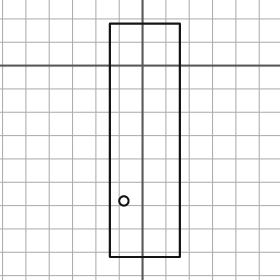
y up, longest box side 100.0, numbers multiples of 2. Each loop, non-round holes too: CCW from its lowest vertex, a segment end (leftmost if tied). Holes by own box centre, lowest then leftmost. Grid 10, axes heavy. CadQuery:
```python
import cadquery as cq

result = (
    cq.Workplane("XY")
    .moveTo(-14.0, -82.0)
    .lineTo(16.0, -82.0)
    .lineTo(16.0, 18.0)
    .lineTo(-14.0, 18.0)
    .close()
    .moveTo(-8.0, -58.0)
    .circle(2.0)
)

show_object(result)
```